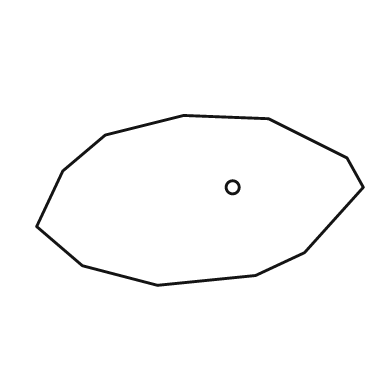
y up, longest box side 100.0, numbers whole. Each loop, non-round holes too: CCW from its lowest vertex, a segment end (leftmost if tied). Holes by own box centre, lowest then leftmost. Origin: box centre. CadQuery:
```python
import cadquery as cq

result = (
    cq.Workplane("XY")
    .moveTo(-13.0, -26.0)
    .lineTo(17.0, -23.0)
    .lineTo(32.0, -16.0)
    .lineTo(50.0, 4.0)
    .lineTo(45.0, 13.0)
    .lineTo(21.0, 25.0)
    .lineTo(-5.0, 26.0)
    .lineTo(-29.0, 20.0)
    .lineTo(-42.0, 9.0)
    .lineTo(-50.0, -8.0)
    .lineTo(-36.0, -20.0)
    .close()
    .moveTo(10.0, 4.0)
    .circle(2.0)
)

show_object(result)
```